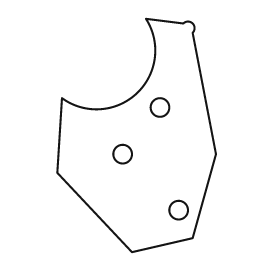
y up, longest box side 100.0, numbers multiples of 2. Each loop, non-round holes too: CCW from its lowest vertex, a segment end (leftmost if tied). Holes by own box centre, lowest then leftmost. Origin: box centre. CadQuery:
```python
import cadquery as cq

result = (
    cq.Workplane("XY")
    .moveTo(-2.0, -50.0)
    .lineTo(24.0, -44.0)
    .lineTo(34.0, -8.0)
    .lineTo(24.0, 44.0)
    .threePointArc((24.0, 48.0), (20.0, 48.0))
    .lineTo(4.0, 50.0)
    .threePointArc((0.0, 18.0), (-32.0, 16.0))
    .lineTo(-34.0, -16.0)
    .close()
    .moveTo(18.0, -32.0)
    .circle(4.0)
    .moveTo(-6.0, -8.0)
    .circle(4.0)
    .moveTo(10.0, 12.0)
    .circle(4.0)
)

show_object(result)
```